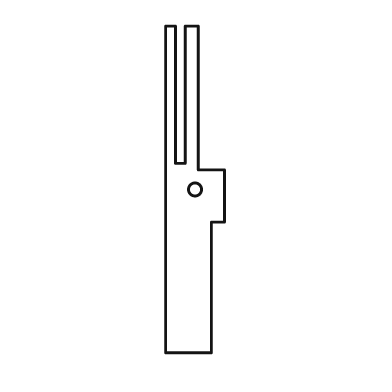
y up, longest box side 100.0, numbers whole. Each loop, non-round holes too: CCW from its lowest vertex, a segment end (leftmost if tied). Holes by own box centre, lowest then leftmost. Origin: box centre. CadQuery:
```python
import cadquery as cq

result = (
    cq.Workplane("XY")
    .moveTo(-9.0, -50.0)
    .lineTo(5.0, -50.0)
    .lineTo(5.0, -10.0)
    .lineTo(9.0, -10.0)
    .lineTo(9.0, 6.0)
    .lineTo(1.0, 6.0)
    .lineTo(1.0, 50.0)
    .lineTo(-3.0, 50.0)
    .lineTo(-3.0, 8.0)
    .lineTo(-6.0, 8.0)
    .lineTo(-6.0, 50.0)
    .lineTo(-9.0, 50.0)
    .close()
    .moveTo(0.0, 0.0)
    .circle(2.0)
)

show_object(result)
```